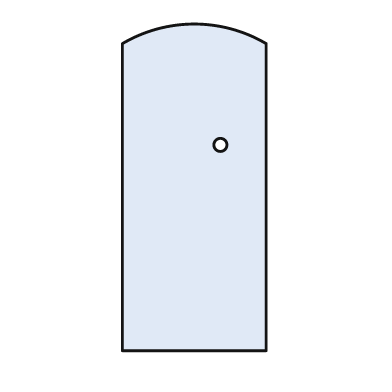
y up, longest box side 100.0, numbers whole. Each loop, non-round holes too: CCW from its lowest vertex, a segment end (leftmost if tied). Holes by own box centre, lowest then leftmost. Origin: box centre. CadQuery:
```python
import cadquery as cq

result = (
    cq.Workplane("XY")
    .moveTo(-22.0, -50.0)
    .lineTo(22.0, -50.0)
    .lineTo(22.0, 44.0)
    .threePointArc((0.0, 50.0), (-22.0, 44.0))
    .close()
    .moveTo(8.0, 13.0)
    .circle(2.0)
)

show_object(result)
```